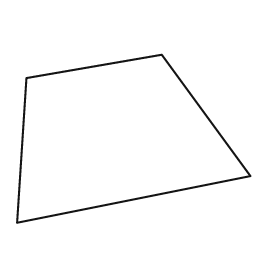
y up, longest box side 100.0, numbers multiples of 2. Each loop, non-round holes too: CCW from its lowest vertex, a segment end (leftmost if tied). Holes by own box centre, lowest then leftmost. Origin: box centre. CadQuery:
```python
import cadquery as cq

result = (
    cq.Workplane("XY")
    .moveTo(-50.0, -36.0)
    .lineTo(50.0, -16.0)
    .lineTo(12.0, 36.0)
    .lineTo(-46.0, 26.0)
    .close()
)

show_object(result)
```